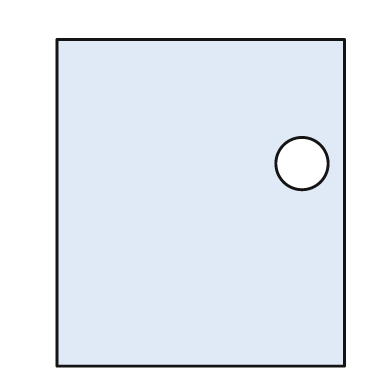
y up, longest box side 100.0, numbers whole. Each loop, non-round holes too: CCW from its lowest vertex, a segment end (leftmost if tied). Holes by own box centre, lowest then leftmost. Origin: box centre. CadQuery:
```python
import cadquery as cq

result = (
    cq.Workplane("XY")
    .moveTo(-44.0, -50.0)
    .lineTo(44.0, -50.0)
    .lineTo(44.0, 50.0)
    .lineTo(-44.0, 50.0)
    .close()
    .moveTo(31.0, 12.0)
    .circle(8.0)
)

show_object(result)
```